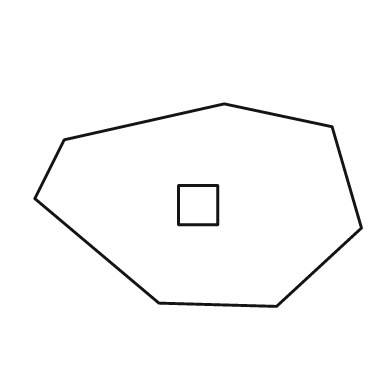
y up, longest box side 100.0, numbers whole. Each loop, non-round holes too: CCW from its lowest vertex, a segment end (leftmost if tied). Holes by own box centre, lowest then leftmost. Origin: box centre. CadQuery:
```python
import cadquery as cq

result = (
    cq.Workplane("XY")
    .moveTo(24.0, -31.0)
    .lineTo(50.0, -7.0)
    .lineTo(41.0, 24.0)
    .lineTo(8.0, 31.0)
    .lineTo(-41.0, 20.0)
    .lineTo(-50.0, 2.0)
    .lineTo(-12.0, -30.0)
    .close()
    .moveTo(-6.0, -6.0)
    .lineTo(6.0, -6.0)
    .lineTo(6.0, 6.0)
    .lineTo(-6.0, 6.0)
    .close()
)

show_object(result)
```